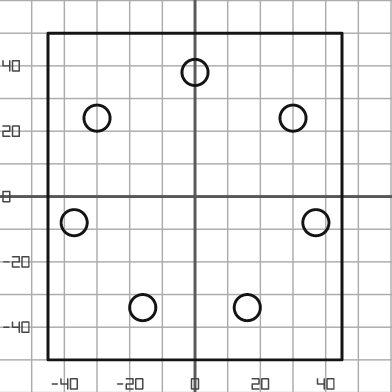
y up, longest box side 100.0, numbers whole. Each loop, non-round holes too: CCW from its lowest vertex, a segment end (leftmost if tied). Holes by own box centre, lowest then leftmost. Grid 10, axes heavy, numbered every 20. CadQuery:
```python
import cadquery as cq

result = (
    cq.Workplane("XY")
    .moveTo(-45.0, -50.0)
    .lineTo(45.0, -50.0)
    .lineTo(45.0, 50.0)
    .lineTo(-45.0, 50.0)
    .close()
    .moveTo(-16.0, -34.0)
    .circle(4.0)
    .moveTo(16.0, -34.0)
    .circle(4.0)
    .moveTo(-37.0, -8.0)
    .circle(4.0)
    .moveTo(37.0, -8.0)
    .circle(4.0)
    .moveTo(-30.0, 24.0)
    .circle(4.0)
    .moveTo(30.0, 24.0)
    .circle(4.0)
    .moveTo(0.0, 38.0)
    .circle(4.0)
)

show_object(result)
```